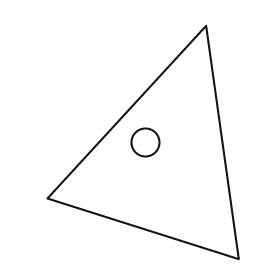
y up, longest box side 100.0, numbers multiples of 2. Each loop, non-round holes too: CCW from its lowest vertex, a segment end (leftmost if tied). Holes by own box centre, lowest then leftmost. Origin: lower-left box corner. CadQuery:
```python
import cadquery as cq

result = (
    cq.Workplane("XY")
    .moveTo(82.0, 0.0)
    .lineTo(68.0, 100.0)
    .lineTo(0.0, 26.0)
    .close()
    .moveTo(42.0, 50.0)
    .circle(6.0)
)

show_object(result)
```